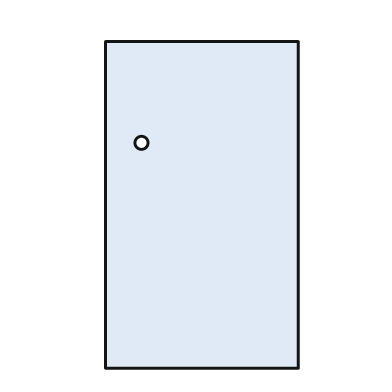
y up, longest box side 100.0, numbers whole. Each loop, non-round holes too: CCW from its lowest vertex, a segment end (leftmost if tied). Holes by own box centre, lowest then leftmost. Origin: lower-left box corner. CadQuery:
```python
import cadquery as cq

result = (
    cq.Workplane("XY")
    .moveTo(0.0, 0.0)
    .lineTo(59.0, 0.0)
    .lineTo(59.0, 100.0)
    .lineTo(0.0, 100.0)
    .close()
    .moveTo(11.0, 69.0)
    .circle(2.0)
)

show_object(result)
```